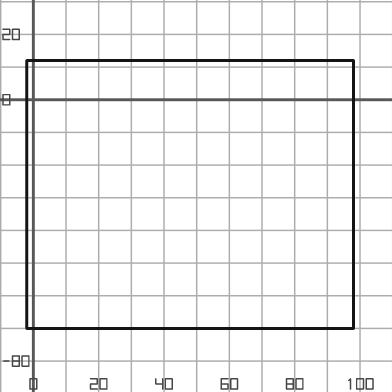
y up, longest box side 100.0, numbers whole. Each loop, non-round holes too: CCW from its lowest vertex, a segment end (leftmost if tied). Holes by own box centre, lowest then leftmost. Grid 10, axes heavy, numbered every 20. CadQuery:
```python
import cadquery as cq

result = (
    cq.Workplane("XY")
    .moveTo(-2.0, -70.0)
    .lineTo(98.0, -70.0)
    .lineTo(98.0, 12.0)
    .lineTo(-2.0, 12.0)
    .close()
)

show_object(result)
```